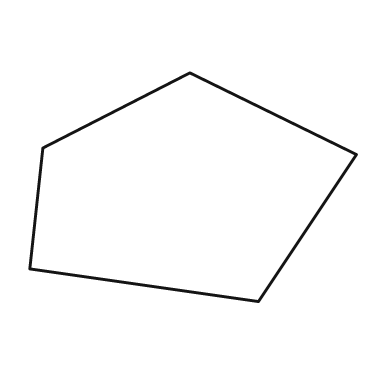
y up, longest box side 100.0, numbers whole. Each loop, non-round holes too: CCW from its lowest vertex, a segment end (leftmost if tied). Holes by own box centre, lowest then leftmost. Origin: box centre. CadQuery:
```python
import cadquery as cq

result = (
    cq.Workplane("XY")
    .moveTo(20.0, -35.0)
    .lineTo(50.0, 10.0)
    .lineTo(-1.0, 35.0)
    .lineTo(-46.0, 12.0)
    .lineTo(-50.0, -25.0)
    .close()
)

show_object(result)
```